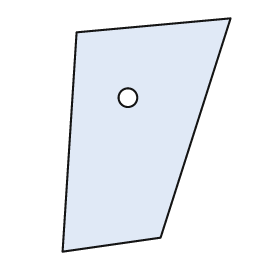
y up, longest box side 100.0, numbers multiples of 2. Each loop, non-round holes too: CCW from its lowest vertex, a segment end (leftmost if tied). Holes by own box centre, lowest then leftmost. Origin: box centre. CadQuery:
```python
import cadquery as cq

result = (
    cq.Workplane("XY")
    .moveTo(-36.0, -50.0)
    .lineTo(6.0, -44.0)
    .lineTo(36.0, 50.0)
    .lineTo(-30.0, 44.0)
    .close()
    .moveTo(-8.0, 16.0)
    .circle(4.0)
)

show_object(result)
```